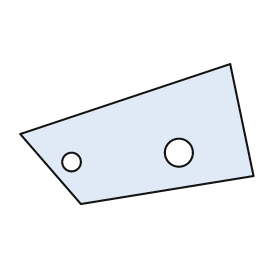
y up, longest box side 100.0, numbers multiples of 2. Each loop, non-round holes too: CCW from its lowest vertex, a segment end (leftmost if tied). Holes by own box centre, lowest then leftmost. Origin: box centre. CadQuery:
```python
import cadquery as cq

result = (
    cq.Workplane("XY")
    .moveTo(-24.0, -30.0)
    .lineTo(50.0, -18.0)
    .lineTo(40.0, 30.0)
    .lineTo(-50.0, 0.0)
    .close()
    .moveTo(-28.0, -12.0)
    .circle(4.0)
    .moveTo(18.0, -8.0)
    .circle(6.0)
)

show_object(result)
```